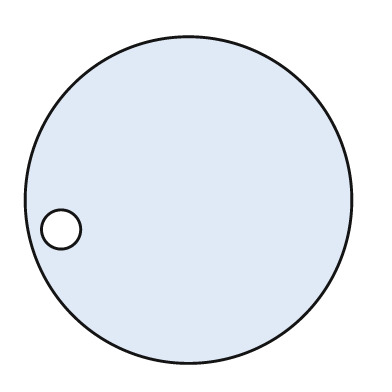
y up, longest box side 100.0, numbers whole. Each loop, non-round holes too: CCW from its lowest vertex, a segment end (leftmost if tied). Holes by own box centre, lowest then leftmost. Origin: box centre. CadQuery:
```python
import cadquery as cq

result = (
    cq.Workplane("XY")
    .moveTo(0.0, 0.0)
    .circle(50.0)
    .moveTo(-39.0, -9.0)
    .circle(6.0)
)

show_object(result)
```